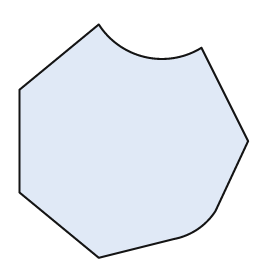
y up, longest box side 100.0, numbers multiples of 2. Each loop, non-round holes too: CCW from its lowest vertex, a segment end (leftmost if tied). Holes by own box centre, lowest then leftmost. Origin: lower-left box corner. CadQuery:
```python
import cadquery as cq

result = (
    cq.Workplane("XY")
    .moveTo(34.0, 0.0)
    .lineTo(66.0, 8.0)
    .threePointArc((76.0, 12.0), (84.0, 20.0))
    .lineTo(98.0, 50.0)
    .lineTo(78.0, 90.0)
    .threePointArc((54.0, 86.0), (34.0, 100.0))
    .lineTo(0.0, 72.0)
    .lineTo(0.0, 28.0)
    .close()
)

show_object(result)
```